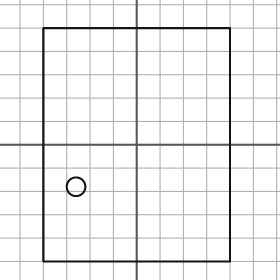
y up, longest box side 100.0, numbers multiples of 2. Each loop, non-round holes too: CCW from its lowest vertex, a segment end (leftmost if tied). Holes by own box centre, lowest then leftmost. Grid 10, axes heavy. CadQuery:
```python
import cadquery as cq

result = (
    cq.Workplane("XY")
    .moveTo(-40.0, -50.0)
    .lineTo(40.0, -50.0)
    .lineTo(40.0, 50.0)
    .lineTo(-40.0, 50.0)
    .close()
    .moveTo(-26.0, -18.0)
    .circle(4.0)
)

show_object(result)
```